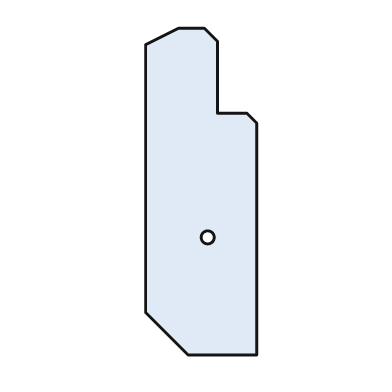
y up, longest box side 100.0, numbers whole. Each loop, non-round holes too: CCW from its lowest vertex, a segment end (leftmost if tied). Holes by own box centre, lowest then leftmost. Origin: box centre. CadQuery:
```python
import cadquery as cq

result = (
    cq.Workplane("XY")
    .moveTo(-4.0, -50.0)
    .lineTo(17.0, -50.0)
    .lineTo(17.0, 21.0)
    .lineTo(14.0, 24.0)
    .lineTo(5.0, 24.0)
    .lineTo(5.0, 46.0)
    .lineTo(1.0, 50.0)
    .lineTo(-7.0, 50.0)
    .lineTo(-17.0, 45.0)
    .lineTo(-17.0, -37.0)
    .close()
    .moveTo(2.0, -14.0)
    .circle(2.0)
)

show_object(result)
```